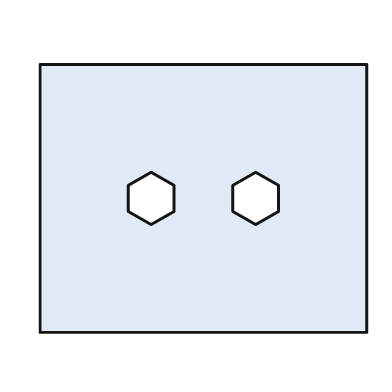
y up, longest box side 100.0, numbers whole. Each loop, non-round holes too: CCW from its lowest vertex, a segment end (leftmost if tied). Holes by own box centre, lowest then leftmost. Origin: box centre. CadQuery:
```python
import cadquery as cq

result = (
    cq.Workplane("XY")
    .moveTo(-50.0, -41.0)
    .lineTo(50.0, -41.0)
    .lineTo(50.0, 41.0)
    .lineTo(-50.0, 41.0)
    .close()
    .moveTo(-16.0, -8.0)
    .lineTo(-9.0, -4.0)
    .lineTo(-9.0, 4.0)
    .lineTo(-16.0, 8.0)
    .lineTo(-23.0, 4.0)
    .lineTo(-23.0, -4.0)
    .close()
    .moveTo(16.0, -8.0)
    .lineTo(23.0, -4.0)
    .lineTo(23.0, 4.0)
    .lineTo(16.0, 8.0)
    .lineTo(9.0, 4.0)
    .lineTo(9.0, -4.0)
    .close()
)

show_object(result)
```